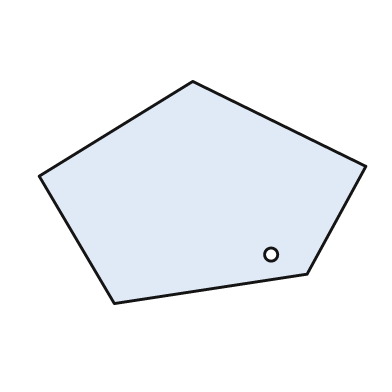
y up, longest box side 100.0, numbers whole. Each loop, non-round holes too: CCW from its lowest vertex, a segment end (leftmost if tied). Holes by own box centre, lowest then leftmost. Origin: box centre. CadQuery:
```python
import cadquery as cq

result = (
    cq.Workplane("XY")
    .moveTo(-27.0, -34.0)
    .lineTo(32.0, -25.0)
    .lineTo(50.0, 8.0)
    .lineTo(-3.0, 34.0)
    .lineTo(-50.0, 5.0)
    .close()
    .moveTo(21.0, -19.0)
    .circle(2.0)
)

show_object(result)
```